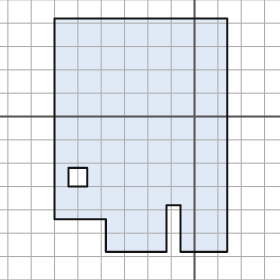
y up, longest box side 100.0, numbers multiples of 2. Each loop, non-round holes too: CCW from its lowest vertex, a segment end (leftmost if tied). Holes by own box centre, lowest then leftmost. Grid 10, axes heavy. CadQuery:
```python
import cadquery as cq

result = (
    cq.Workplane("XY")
    .moveTo(-38.0, -58.0)
    .lineTo(-12.0, -58.0)
    .lineTo(-12.0, -38.0)
    .lineTo(-6.0, -38.0)
    .lineTo(-6.0, -58.0)
    .lineTo(14.0, -58.0)
    .lineTo(14.0, 42.0)
    .lineTo(-60.0, 42.0)
    .lineTo(-60.0, -44.0)
    .lineTo(-38.0, -44.0)
    .close()
    .moveTo(-54.0, -30.0)
    .lineTo(-46.0, -30.0)
    .lineTo(-46.0, -22.0)
    .lineTo(-54.0, -22.0)
    .close()
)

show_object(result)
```